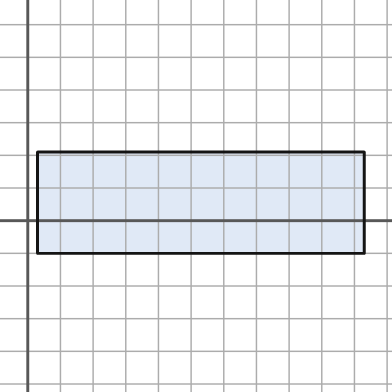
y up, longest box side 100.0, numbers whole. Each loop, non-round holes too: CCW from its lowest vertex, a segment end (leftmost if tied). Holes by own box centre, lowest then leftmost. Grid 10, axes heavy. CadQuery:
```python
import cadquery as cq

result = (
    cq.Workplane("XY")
    .moveTo(3.0, -10.0)
    .lineTo(103.0, -10.0)
    .lineTo(103.0, 21.0)
    .lineTo(3.0, 21.0)
    .close()
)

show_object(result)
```